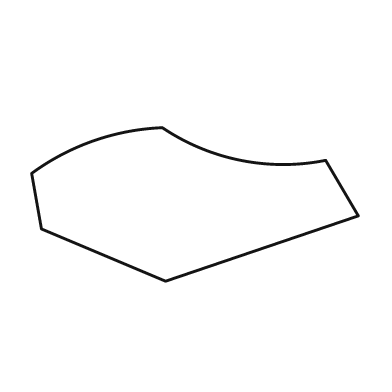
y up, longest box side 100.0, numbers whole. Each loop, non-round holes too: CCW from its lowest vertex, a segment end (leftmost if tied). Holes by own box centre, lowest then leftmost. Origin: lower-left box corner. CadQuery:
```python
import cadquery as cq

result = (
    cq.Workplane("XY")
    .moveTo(41.0, 0.0)
    .lineTo(100.0, 20.0)
    .lineTo(90.0, 37.0)
    .threePointArc((64.0, 37.0), (40.0, 47.0))
    .threePointArc((19.0, 43.0), (0.0, 33.0))
    .lineTo(3.0, 16.0)
    .close()
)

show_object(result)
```